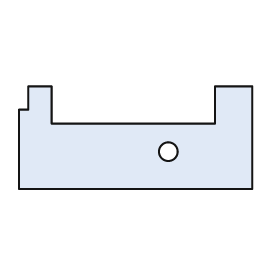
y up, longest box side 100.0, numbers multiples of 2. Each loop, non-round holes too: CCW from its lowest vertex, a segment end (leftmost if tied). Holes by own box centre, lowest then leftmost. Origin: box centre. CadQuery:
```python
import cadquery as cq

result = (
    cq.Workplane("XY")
    .moveTo(-50.0, -22.0)
    .lineTo(50.0, -22.0)
    .lineTo(50.0, 22.0)
    .lineTo(34.0, 22.0)
    .lineTo(34.0, 6.0)
    .lineTo(-36.0, 6.0)
    .lineTo(-36.0, 22.0)
    .lineTo(-46.0, 22.0)
    .lineTo(-46.0, 12.0)
    .lineTo(-50.0, 12.0)
    .close()
    .moveTo(14.0, -6.0)
    .circle(4.0)
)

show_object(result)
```